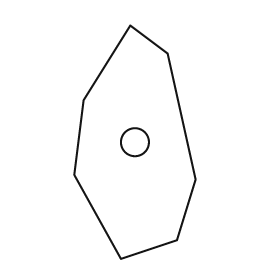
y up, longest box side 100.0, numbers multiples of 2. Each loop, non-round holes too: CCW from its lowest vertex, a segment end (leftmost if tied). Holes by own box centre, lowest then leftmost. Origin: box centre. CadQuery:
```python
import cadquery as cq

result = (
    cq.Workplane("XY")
    .moveTo(-6.0, -50.0)
    .lineTo(18.0, -42.0)
    .lineTo(26.0, -16.0)
    .lineTo(14.0, 38.0)
    .lineTo(-2.0, 50.0)
    .lineTo(-22.0, 18.0)
    .lineTo(-26.0, -14.0)
    .close()
    .moveTo(0.0, 0.0)
    .circle(6.0)
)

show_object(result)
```